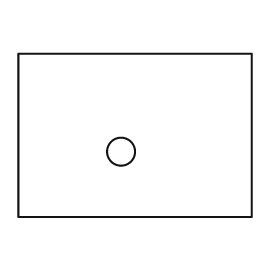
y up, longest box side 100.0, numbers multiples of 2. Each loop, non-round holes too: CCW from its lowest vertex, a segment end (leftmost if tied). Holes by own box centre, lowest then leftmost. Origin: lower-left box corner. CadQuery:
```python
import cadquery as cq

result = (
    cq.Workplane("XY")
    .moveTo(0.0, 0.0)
    .lineTo(100.0, 0.0)
    .lineTo(100.0, 70.0)
    .lineTo(0.0, 70.0)
    .close()
    .moveTo(44.0, 28.0)
    .circle(6.0)
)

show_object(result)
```